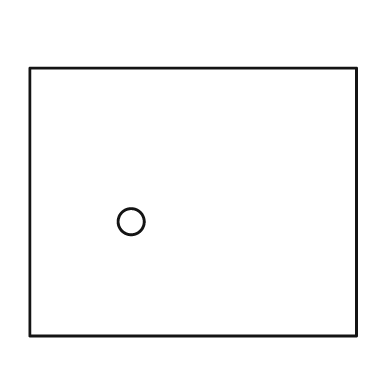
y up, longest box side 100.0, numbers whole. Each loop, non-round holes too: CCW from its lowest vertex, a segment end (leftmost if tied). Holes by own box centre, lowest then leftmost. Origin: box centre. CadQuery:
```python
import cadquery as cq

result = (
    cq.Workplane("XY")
    .moveTo(-50.0, -41.0)
    .lineTo(50.0, -41.0)
    .lineTo(50.0, 41.0)
    .lineTo(-50.0, 41.0)
    .close()
    .moveTo(-19.0, -6.0)
    .circle(4.0)
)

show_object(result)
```